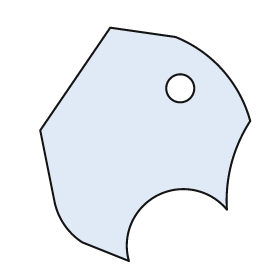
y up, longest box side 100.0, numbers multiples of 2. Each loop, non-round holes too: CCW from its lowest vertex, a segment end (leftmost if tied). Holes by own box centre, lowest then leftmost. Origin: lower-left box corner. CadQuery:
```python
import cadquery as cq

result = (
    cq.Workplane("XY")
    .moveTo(38.0, 0.0)
    .threePointArc((50.0, 28.0), (80.0, 22.0))
    .threePointArc((82.0, 42.0), (90.0, 60.0))
    .threePointArc((78.0, 82.0), (58.0, 96.0))
    .lineTo(30.0, 100.0)
    .lineTo(0.0, 56.0)
    .lineTo(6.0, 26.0)
    .threePointArc((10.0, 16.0), (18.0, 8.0))
    .close()
    .moveTo(60.0, 74.0)
    .circle(6.0)
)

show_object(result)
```